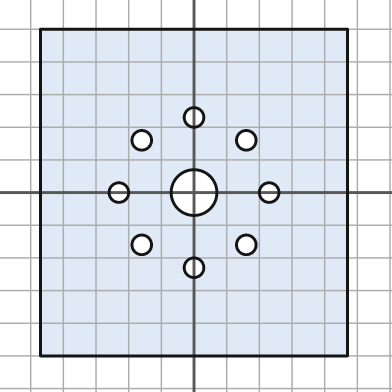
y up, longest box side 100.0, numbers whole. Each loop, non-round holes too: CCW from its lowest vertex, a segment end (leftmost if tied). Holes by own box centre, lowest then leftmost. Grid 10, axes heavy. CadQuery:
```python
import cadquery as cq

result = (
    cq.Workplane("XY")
    .moveTo(-47.0, -50.0)
    .lineTo(47.0, -50.0)
    .lineTo(47.0, 50.0)
    .lineTo(-47.0, 50.0)
    .close()
    .moveTo(0.0, -23.0)
    .circle(3.0)
    .moveTo(-16.0, -16.0)
    .circle(3.0)
    .moveTo(16.0, -16.0)
    .circle(3.0)
    .moveTo(-23.0, 0.0)
    .circle(3.0)
    .moveTo(0.0, 0.0)
    .circle(7.0)
    .moveTo(23.0, 0.0)
    .circle(3.0)
    .moveTo(-16.0, 16.0)
    .circle(3.0)
    .moveTo(16.0, 16.0)
    .circle(3.0)
    .moveTo(0.0, 23.0)
    .circle(3.0)
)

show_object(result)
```